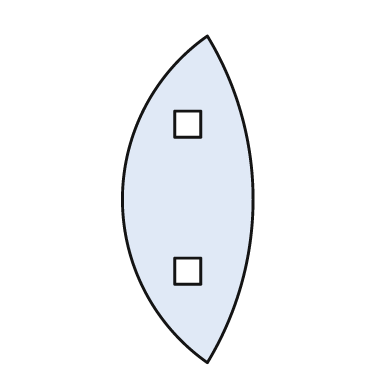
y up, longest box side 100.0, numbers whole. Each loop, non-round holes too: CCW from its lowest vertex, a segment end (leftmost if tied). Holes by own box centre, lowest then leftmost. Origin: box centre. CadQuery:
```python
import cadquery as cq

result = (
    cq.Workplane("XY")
    .moveTo(6.0, -50.0)
    .threePointArc((20.0, 0.0), (6.0, 50.0))
    .threePointArc((-20.0, 0.0), (6.0, -50.0))
    .close()
    .moveTo(-4.0, -26.0)
    .lineTo(4.0, -26.0)
    .lineTo(4.0, -18.0)
    .lineTo(-4.0, -18.0)
    .close()
    .moveTo(-4.0, 19.0)
    .lineTo(4.0, 19.0)
    .lineTo(4.0, 27.0)
    .lineTo(-4.0, 27.0)
    .close()
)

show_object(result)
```